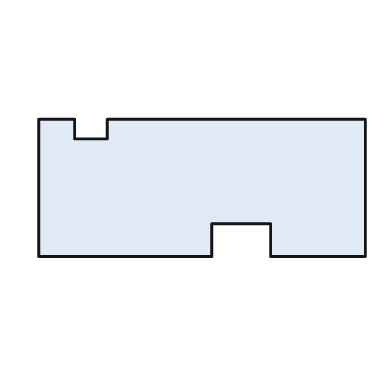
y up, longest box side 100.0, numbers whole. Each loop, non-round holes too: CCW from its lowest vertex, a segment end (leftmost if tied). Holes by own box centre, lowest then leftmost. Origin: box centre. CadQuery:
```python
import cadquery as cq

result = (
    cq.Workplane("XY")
    .moveTo(-50.0, -21.0)
    .lineTo(3.0, -21.0)
    .lineTo(3.0, -11.0)
    .lineTo(21.0, -11.0)
    .lineTo(21.0, -21.0)
    .lineTo(50.0, -21.0)
    .lineTo(50.0, 21.0)
    .lineTo(-29.0, 21.0)
    .lineTo(-29.0, 15.0)
    .lineTo(-39.0, 15.0)
    .lineTo(-39.0, 21.0)
    .lineTo(-50.0, 21.0)
    .close()
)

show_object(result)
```